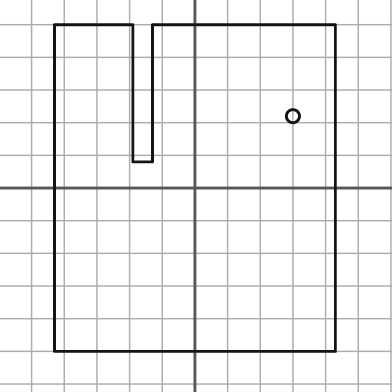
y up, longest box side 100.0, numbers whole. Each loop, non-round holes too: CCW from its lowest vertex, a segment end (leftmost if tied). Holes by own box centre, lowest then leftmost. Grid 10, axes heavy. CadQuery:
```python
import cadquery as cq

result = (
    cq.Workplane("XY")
    .moveTo(-43.0, -50.0)
    .lineTo(43.0, -50.0)
    .lineTo(43.0, 50.0)
    .lineTo(-13.0, 50.0)
    .lineTo(-13.0, 8.0)
    .lineTo(-19.0, 8.0)
    .lineTo(-19.0, 50.0)
    .lineTo(-43.0, 50.0)
    .close()
    .moveTo(30.0, 22.0)
    .circle(2.0)
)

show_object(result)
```